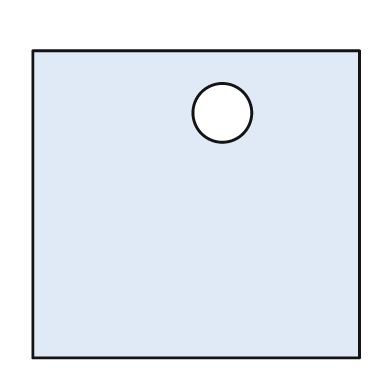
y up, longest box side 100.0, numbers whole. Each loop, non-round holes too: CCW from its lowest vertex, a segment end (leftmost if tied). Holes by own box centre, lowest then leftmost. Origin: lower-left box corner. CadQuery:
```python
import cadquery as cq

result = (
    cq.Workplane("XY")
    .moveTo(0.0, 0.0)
    .lineTo(100.0, 0.0)
    .lineTo(100.0, 94.0)
    .lineTo(0.0, 94.0)
    .close()
    .moveTo(58.0, 75.0)
    .circle(9.0)
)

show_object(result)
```